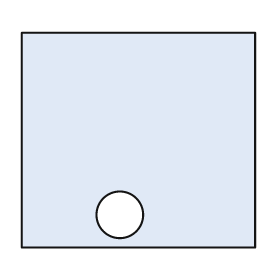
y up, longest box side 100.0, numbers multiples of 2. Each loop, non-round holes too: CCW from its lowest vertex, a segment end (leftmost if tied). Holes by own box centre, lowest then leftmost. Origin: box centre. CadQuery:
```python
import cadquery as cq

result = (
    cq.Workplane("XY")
    .moveTo(-50.0, -46.0)
    .lineTo(50.0, -46.0)
    .lineTo(50.0, 46.0)
    .lineTo(-50.0, 46.0)
    .close()
    .moveTo(-8.0, -32.0)
    .circle(10.0)
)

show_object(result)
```